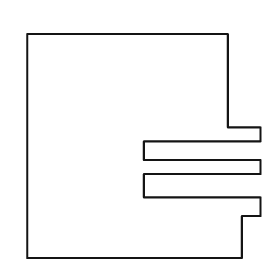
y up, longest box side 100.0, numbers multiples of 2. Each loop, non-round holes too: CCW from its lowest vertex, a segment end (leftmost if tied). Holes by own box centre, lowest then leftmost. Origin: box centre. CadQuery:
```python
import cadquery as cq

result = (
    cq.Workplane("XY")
    .moveTo(-50.0, -48.0)
    .lineTo(42.0, -48.0)
    .lineTo(42.0, -30.0)
    .lineTo(50.0, -30.0)
    .lineTo(50.0, -22.0)
    .lineTo(0.0, -22.0)
    .lineTo(0.0, -12.0)
    .lineTo(50.0, -12.0)
    .lineTo(50.0, -6.0)
    .lineTo(0.0, -6.0)
    .lineTo(0.0, 2.0)
    .lineTo(50.0, 2.0)
    .lineTo(50.0, 8.0)
    .lineTo(36.0, 8.0)
    .lineTo(36.0, 48.0)
    .lineTo(-50.0, 48.0)
    .close()
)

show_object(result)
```